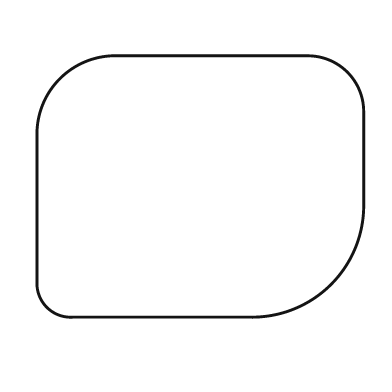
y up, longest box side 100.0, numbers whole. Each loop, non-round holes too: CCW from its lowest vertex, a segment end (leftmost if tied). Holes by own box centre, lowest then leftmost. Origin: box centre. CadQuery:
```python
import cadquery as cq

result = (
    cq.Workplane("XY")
    .moveTo(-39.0, -40.0)
    .lineTo(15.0, -40.0)
    .threePointArc((40.0, -30.0), (50.0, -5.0))
    .lineTo(50.0, 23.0)
    .threePointArc((45.0, 35.0), (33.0, 40.0))
    .lineTo(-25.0, 40.0)
    .threePointArc((-43.0, 33.0), (-50.0, 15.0))
    .lineTo(-50.0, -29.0)
    .threePointArc((-47.0, -37.0), (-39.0, -40.0))
    .close()
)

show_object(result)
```